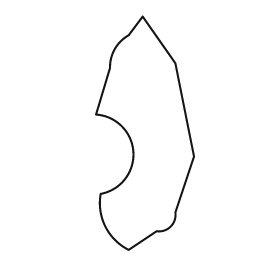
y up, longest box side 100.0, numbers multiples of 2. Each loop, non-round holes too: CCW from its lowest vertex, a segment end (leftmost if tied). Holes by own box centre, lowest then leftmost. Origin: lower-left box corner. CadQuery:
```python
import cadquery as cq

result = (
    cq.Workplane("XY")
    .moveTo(14.0, 0.0)
    .lineTo(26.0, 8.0)
    .threePointArc((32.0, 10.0), (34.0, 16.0))
    .lineTo(42.0, 40.0)
    .lineTo(34.0, 80.0)
    .lineTo(20.0, 100.0)
    .lineTo(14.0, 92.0)
    .threePointArc((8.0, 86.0), (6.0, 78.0))
    .lineTo(0.0, 58.0)
    .threePointArc((16.0, 42.0), (2.0, 24.0))
    .threePointArc((4.0, 10.0), (14.0, 0.0))
    .close()
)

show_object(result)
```